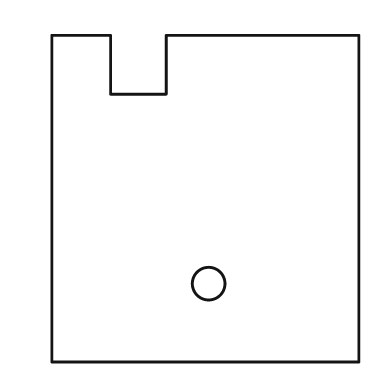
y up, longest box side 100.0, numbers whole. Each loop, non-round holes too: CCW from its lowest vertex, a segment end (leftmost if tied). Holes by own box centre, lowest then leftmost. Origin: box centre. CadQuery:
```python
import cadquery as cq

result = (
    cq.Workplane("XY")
    .moveTo(-47.0, -50.0)
    .lineTo(47.0, -50.0)
    .lineTo(47.0, 50.0)
    .lineTo(-12.0, 50.0)
    .lineTo(-12.0, 32.0)
    .lineTo(-29.0, 32.0)
    .lineTo(-29.0, 50.0)
    .lineTo(-47.0, 50.0)
    .close()
    .moveTo(1.0, -26.0)
    .circle(5.0)
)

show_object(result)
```